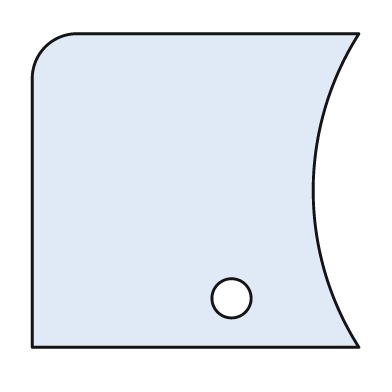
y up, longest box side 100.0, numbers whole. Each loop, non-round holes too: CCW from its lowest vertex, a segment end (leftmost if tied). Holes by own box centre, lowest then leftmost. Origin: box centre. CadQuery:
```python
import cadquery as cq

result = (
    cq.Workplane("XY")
    .moveTo(-50.0, -48.0)
    .lineTo(50.0, -48.0)
    .threePointArc((36.0, 0.0), (50.0, 48.0))
    .lineTo(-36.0, 48.0)
    .threePointArc((-46.0, 44.0), (-50.0, 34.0))
    .close()
    .moveTo(11.0, -33.0)
    .circle(6.0)
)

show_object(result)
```